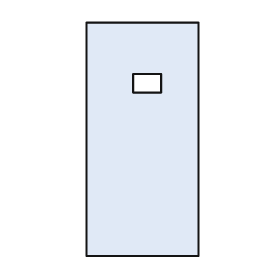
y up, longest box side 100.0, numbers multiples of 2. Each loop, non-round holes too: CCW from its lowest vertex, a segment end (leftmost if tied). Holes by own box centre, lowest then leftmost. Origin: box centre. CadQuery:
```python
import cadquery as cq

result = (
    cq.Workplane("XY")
    .moveTo(-24.0, -50.0)
    .lineTo(24.0, -50.0)
    .lineTo(24.0, 50.0)
    .lineTo(-24.0, 50.0)
    .close()
    .moveTo(-4.0, 20.0)
    .lineTo(8.0, 20.0)
    .lineTo(8.0, 28.0)
    .lineTo(-4.0, 28.0)
    .close()
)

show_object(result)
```